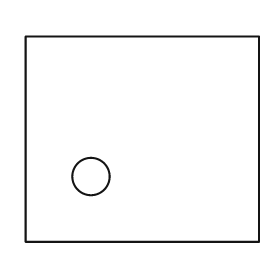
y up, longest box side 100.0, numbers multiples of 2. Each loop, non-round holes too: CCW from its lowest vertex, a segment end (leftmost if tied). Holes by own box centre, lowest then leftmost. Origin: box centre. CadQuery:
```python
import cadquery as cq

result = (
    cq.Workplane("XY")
    .moveTo(-50.0, -44.0)
    .lineTo(50.0, -44.0)
    .lineTo(50.0, 44.0)
    .lineTo(-50.0, 44.0)
    .close()
    .moveTo(-22.0, -16.0)
    .circle(8.0)
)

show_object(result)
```